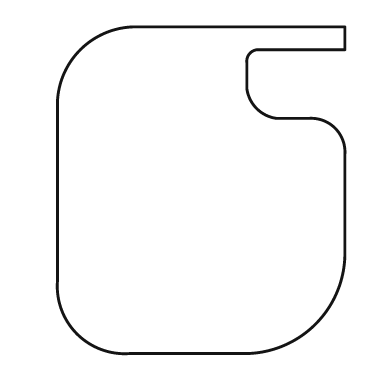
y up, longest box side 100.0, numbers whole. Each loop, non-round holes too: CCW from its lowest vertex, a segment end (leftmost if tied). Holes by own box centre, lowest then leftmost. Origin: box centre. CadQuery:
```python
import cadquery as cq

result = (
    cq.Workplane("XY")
    .moveTo(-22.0, -50.0)
    .lineTo(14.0, -50.0)
    .threePointArc((35.0, -41.0), (44.0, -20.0))
    .lineTo(44.0, 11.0)
    .threePointArc((41.0, 19.0), (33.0, 22.0))
    .lineTo(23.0, 22.0)
    .threePointArc((17.0, 25.0), (14.0, 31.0))
    .lineTo(14.0, 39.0)
    .threePointArc((15.0, 42.0), (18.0, 43.0))
    .lineTo(44.0, 43.0)
    .lineTo(44.0, 50.0)
    .lineTo(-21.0, 50.0)
    .threePointArc((-37.0, 43.0), (-44.0, 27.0))
    .lineTo(-44.0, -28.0)
    .threePointArc((-38.0, -44.0), (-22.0, -50.0))
    .close()
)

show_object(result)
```